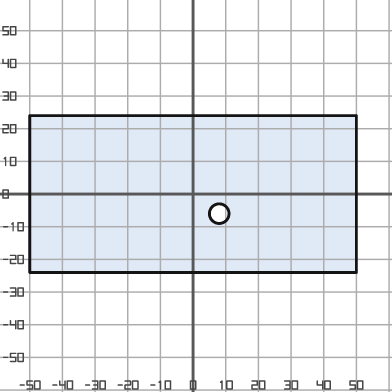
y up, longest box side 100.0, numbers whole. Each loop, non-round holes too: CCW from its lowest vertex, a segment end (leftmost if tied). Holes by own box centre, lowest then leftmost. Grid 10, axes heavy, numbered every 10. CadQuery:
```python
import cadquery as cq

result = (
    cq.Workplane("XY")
    .moveTo(-50.0, -24.0)
    .lineTo(50.0, -24.0)
    .lineTo(50.0, 24.0)
    .lineTo(-50.0, 24.0)
    .close()
    .moveTo(8.0, -6.0)
    .circle(3.0)
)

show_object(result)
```